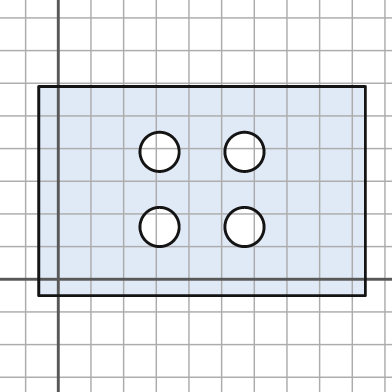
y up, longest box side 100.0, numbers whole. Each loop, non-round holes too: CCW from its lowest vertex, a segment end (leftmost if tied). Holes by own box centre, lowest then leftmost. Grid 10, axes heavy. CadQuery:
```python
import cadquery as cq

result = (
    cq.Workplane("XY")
    .moveTo(-6.0, -5.0)
    .lineTo(94.0, -5.0)
    .lineTo(94.0, 59.0)
    .lineTo(-6.0, 59.0)
    .close()
    .moveTo(31.0, 16.0)
    .circle(6.0)
    .moveTo(57.0, 16.0)
    .circle(6.0)
    .moveTo(31.0, 39.0)
    .circle(6.0)
    .moveTo(57.0, 39.0)
    .circle(6.0)
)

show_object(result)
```